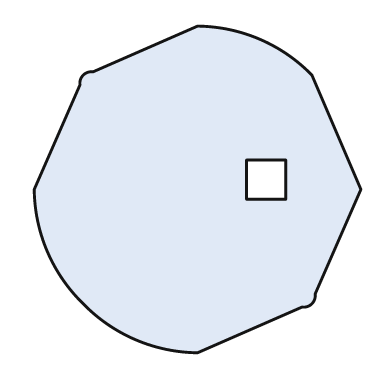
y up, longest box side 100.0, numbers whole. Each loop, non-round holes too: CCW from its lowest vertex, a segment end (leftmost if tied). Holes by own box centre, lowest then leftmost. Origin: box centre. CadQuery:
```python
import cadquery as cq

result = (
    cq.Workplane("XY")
    .moveTo(0.0, -50.0)
    .lineTo(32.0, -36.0)
    .threePointArc((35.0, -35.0), (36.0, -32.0))
    .lineTo(50.0, 0.0)
    .lineTo(35.0, 35.0)
    .threePointArc((19.0, 46.0), (0.0, 50.0))
    .lineTo(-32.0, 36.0)
    .threePointArc((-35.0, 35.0), (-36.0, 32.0))
    .lineTo(-50.0, 0.0)
    .threePointArc((-46.0, -19.0), (-35.0, -35.0))
    .threePointArc((-19.0, -46.0), (0.0, -50.0))
    .close()
    .moveTo(15.0, -3.0)
    .lineTo(27.0, -3.0)
    .lineTo(27.0, 9.0)
    .lineTo(15.0, 9.0)
    .close()
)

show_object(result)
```